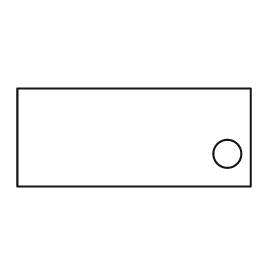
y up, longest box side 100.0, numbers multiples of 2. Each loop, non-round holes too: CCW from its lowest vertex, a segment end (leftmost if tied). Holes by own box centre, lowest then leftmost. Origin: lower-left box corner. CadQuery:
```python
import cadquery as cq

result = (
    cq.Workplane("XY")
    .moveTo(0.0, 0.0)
    .lineTo(100.0, 0.0)
    .lineTo(100.0, 42.0)
    .lineTo(0.0, 42.0)
    .close()
    .moveTo(90.0, 14.0)
    .circle(6.0)
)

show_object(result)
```